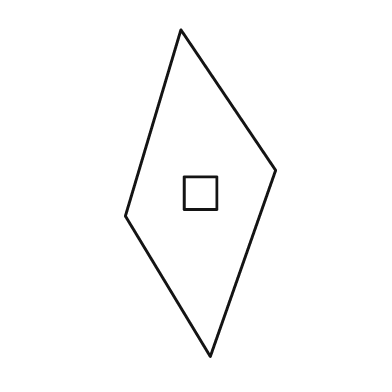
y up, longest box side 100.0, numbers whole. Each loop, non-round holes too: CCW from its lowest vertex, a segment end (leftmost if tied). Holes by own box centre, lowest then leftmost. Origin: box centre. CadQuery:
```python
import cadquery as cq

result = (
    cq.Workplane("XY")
    .moveTo(3.0, -50.0)
    .lineTo(23.0, 7.0)
    .lineTo(-6.0, 50.0)
    .lineTo(-23.0, -7.0)
    .close()
    .moveTo(-5.0, -5.0)
    .lineTo(5.0, -5.0)
    .lineTo(5.0, 5.0)
    .lineTo(-5.0, 5.0)
    .close()
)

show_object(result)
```